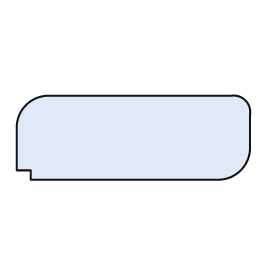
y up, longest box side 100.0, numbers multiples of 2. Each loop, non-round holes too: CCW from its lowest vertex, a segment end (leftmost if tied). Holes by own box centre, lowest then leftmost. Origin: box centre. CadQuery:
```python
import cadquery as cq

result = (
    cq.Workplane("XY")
    .moveTo(-44.0, -18.0)
    .lineTo(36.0, -18.0)
    .threePointArc((46.0, -14.0), (50.0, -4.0))
    .lineTo(50.0, 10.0)
    .threePointArc((48.0, 16.0), (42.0, 18.0))
    .lineTo(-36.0, 18.0)
    .threePointArc((-46.0, 14.0), (-50.0, 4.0))
    .lineTo(-50.0, -14.0)
    .lineTo(-44.0, -14.0)
    .close()
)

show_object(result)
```